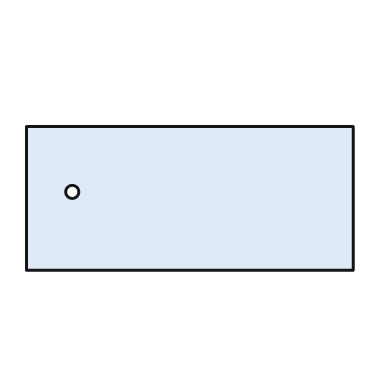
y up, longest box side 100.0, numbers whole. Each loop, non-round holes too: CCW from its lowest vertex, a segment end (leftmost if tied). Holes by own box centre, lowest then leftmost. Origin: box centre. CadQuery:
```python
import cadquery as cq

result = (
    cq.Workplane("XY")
    .moveTo(-50.0, -22.0)
    .lineTo(50.0, -22.0)
    .lineTo(50.0, 22.0)
    .lineTo(-50.0, 22.0)
    .close()
    .moveTo(-36.0, 2.0)
    .circle(2.0)
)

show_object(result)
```